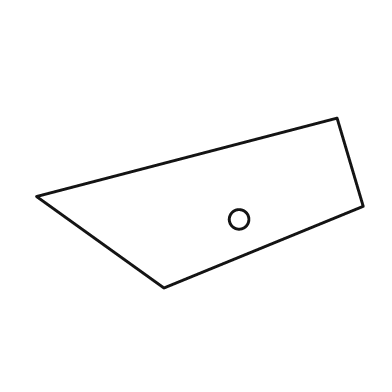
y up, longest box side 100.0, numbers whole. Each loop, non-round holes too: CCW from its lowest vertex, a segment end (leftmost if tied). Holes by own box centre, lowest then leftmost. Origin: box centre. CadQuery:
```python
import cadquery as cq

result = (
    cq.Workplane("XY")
    .moveTo(-11.0, -26.0)
    .lineTo(50.0, -1.0)
    .lineTo(42.0, 26.0)
    .lineTo(-50.0, 2.0)
    .close()
    .moveTo(12.0, -5.0)
    .circle(3.0)
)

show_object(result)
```